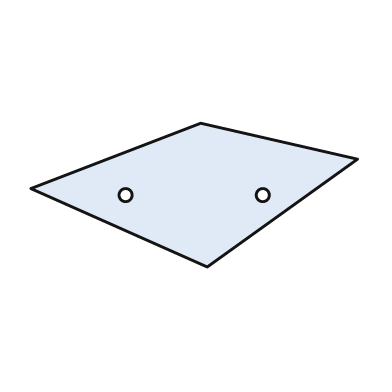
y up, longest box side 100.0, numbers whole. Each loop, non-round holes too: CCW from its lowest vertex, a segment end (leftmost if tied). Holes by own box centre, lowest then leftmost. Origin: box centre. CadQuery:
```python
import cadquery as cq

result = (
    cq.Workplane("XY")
    .moveTo(4.0, -22.0)
    .lineTo(50.0, 11.0)
    .lineTo(2.0, 22.0)
    .lineTo(-50.0, 2.0)
    .close()
    .moveTo(-21.0, 0.0)
    .circle(2.0)
    .moveTo(21.0, 0.0)
    .circle(2.0)
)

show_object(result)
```